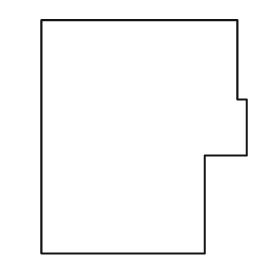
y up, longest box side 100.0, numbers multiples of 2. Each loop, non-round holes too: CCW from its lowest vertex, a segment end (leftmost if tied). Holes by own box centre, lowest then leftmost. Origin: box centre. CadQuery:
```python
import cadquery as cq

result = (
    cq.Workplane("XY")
    .moveTo(-44.0, -50.0)
    .lineTo(26.0, -50.0)
    .lineTo(26.0, -8.0)
    .lineTo(44.0, -8.0)
    .lineTo(44.0, 16.0)
    .lineTo(40.0, 16.0)
    .lineTo(40.0, 50.0)
    .lineTo(-44.0, 50.0)
    .close()
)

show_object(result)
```